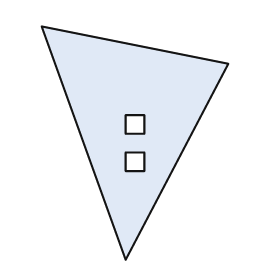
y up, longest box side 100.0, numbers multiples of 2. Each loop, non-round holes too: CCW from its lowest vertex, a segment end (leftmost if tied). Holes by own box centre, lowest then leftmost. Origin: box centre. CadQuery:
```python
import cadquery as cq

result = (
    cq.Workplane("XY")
    .moveTo(-4.0, -50.0)
    .lineTo(40.0, 34.0)
    .lineTo(-40.0, 50.0)
    .close()
    .moveTo(-4.0, -12.0)
    .lineTo(4.0, -12.0)
    .lineTo(4.0, -4.0)
    .lineTo(-4.0, -4.0)
    .close()
    .moveTo(-4.0, 4.0)
    .lineTo(4.0, 4.0)
    .lineTo(4.0, 12.0)
    .lineTo(-4.0, 12.0)
    .close()
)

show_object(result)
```